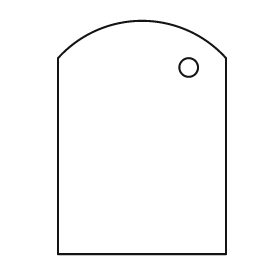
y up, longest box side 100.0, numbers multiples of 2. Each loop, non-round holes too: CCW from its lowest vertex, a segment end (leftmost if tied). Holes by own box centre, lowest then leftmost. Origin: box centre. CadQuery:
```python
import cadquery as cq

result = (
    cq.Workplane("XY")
    .moveTo(-36.0, -50.0)
    .lineTo(36.0, -50.0)
    .lineTo(36.0, 34.0)
    .threePointArc((0.0, 50.0), (-36.0, 34.0))
    .close()
    .moveTo(20.0, 30.0)
    .circle(4.0)
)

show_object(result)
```